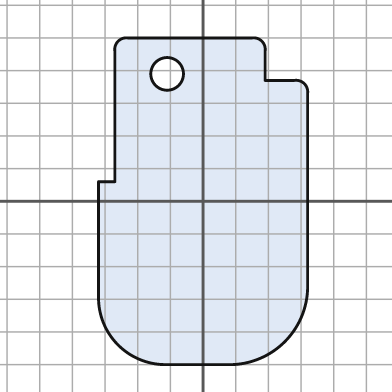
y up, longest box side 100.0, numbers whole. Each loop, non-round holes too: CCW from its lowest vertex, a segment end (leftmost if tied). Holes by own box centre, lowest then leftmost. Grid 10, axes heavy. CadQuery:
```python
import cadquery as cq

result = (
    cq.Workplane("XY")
    .moveTo(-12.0, -50.0)
    .lineTo(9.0, -50.0)
    .threePointArc((25.0, -43.0), (32.0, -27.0))
    .lineTo(32.0, 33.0)
    .threePointArc((31.0, 36.0), (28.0, 37.0))
    .lineTo(19.0, 37.0)
    .lineTo(19.0, 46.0)
    .threePointArc((18.0, 49.0), (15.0, 50.0))
    .lineTo(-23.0, 50.0)
    .threePointArc((-26.0, 49.0), (-27.0, 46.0))
    .lineTo(-27.0, 6.0)
    .lineTo(-32.0, 6.0)
    .lineTo(-32.0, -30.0)
    .threePointArc((-26.0, -44.0), (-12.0, -50.0))
    .close()
    .moveTo(-11.0, 39.0)
    .circle(5.0)
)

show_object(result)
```